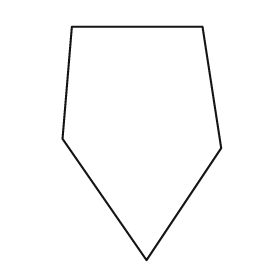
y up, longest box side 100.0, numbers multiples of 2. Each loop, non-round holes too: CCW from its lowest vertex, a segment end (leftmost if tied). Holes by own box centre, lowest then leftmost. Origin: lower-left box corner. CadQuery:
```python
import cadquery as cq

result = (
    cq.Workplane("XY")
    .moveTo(36.0, 0.0)
    .lineTo(68.0, 48.0)
    .lineTo(60.0, 100.0)
    .lineTo(4.0, 100.0)
    .lineTo(0.0, 52.0)
    .close()
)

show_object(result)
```